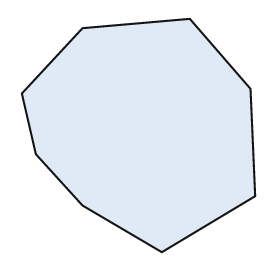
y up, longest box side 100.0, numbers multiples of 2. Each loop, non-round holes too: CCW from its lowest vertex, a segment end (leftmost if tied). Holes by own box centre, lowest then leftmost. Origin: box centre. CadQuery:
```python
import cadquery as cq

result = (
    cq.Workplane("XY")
    .moveTo(10.0, -50.0)
    .lineTo(50.0, -26.0)
    .lineTo(48.0, 20.0)
    .lineTo(22.0, 50.0)
    .lineTo(-24.0, 46.0)
    .lineTo(-50.0, 18.0)
    .lineTo(-44.0, -8.0)
    .lineTo(-24.0, -30.0)
    .close()
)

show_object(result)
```